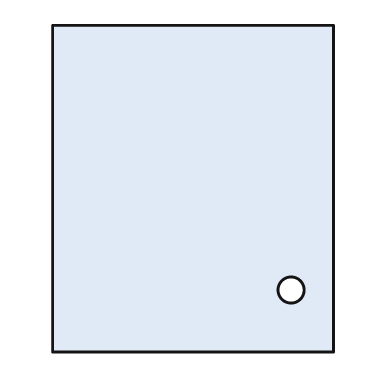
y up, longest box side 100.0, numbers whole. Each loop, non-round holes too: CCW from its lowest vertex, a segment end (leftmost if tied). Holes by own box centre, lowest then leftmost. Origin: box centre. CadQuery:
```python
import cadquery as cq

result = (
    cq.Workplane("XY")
    .moveTo(-43.0, -50.0)
    .lineTo(43.0, -50.0)
    .lineTo(43.0, 50.0)
    .lineTo(-43.0, 50.0)
    .close()
    .moveTo(30.0, -31.0)
    .circle(4.0)
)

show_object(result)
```